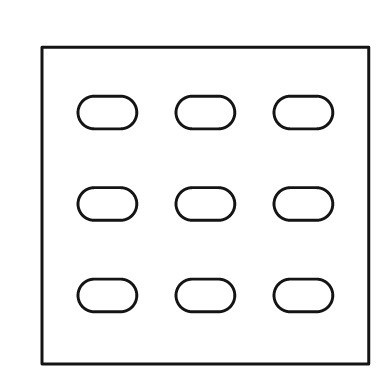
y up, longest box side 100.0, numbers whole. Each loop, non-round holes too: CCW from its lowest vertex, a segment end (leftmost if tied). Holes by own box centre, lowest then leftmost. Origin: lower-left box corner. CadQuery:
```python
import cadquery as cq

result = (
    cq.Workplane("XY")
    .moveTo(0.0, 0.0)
    .lineTo(100.0, 0.0)
    .lineTo(100.0, 97.0)
    .lineTo(0.0, 97.0)
    .close()
    .moveTo(16.0, 16.0)
    .lineTo(24.0, 16.0)
    .threePointArc((29.0, 21.0), (24.0, 26.0))
    .lineTo(16.0, 26.0)
    .threePointArc((11.0, 21.0), (16.0, 16.0))
    .close()
    .moveTo(46.0, 16.0)
    .lineTo(54.0, 16.0)
    .threePointArc((59.0, 21.0), (54.0, 26.0))
    .lineTo(46.0, 26.0)
    .threePointArc((41.0, 21.0), (46.0, 16.0))
    .close()
    .moveTo(76.0, 16.0)
    .lineTo(84.0, 16.0)
    .threePointArc((89.0, 21.0), (84.0, 26.0))
    .lineTo(76.0, 26.0)
    .threePointArc((71.0, 21.0), (76.0, 16.0))
    .close()
    .moveTo(16.0, 44.0)
    .lineTo(24.0, 44.0)
    .threePointArc((29.0, 49.0), (24.0, 54.0))
    .lineTo(16.0, 54.0)
    .threePointArc((11.0, 49.0), (16.0, 44.0))
    .close()
    .moveTo(46.0, 44.0)
    .lineTo(54.0, 44.0)
    .threePointArc((59.0, 49.0), (54.0, 54.0))
    .lineTo(46.0, 54.0)
    .threePointArc((41.0, 49.0), (46.0, 44.0))
    .close()
    .moveTo(76.0, 44.0)
    .lineTo(84.0, 44.0)
    .threePointArc((89.0, 49.0), (84.0, 54.0))
    .lineTo(76.0, 54.0)
    .threePointArc((71.0, 49.0), (76.0, 44.0))
    .close()
    .moveTo(16.0, 72.0)
    .lineTo(24.0, 72.0)
    .threePointArc((29.0, 77.0), (24.0, 82.0))
    .lineTo(16.0, 82.0)
    .threePointArc((11.0, 77.0), (16.0, 72.0))
    .close()
    .moveTo(46.0, 72.0)
    .lineTo(54.0, 72.0)
    .threePointArc((59.0, 77.0), (54.0, 82.0))
    .lineTo(46.0, 82.0)
    .threePointArc((41.0, 77.0), (46.0, 72.0))
    .close()
    .moveTo(76.0, 72.0)
    .lineTo(84.0, 72.0)
    .threePointArc((89.0, 77.0), (84.0, 82.0))
    .lineTo(76.0, 82.0)
    .threePointArc((71.0, 77.0), (76.0, 72.0))
    .close()
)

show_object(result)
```